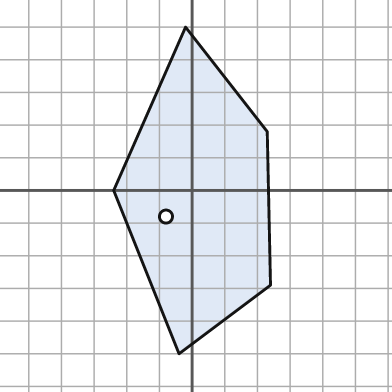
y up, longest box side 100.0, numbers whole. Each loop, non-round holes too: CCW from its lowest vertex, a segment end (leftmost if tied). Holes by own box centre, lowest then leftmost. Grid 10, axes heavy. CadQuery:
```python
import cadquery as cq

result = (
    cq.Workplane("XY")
    .moveTo(-4.0, -50.0)
    .lineTo(24.0, -29.0)
    .lineTo(23.0, 18.0)
    .lineTo(-2.0, 50.0)
    .lineTo(-24.0, 0.0)
    .close()
    .moveTo(-8.0, -8.0)
    .circle(2.0)
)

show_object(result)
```